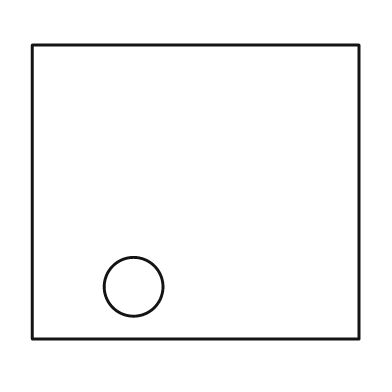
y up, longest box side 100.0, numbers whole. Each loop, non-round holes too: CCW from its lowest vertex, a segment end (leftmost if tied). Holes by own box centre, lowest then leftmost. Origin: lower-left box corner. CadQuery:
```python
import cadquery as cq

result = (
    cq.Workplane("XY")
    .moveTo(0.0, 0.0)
    .lineTo(100.0, 0.0)
    .lineTo(100.0, 90.0)
    .lineTo(0.0, 90.0)
    .close()
    .moveTo(31.0, 16.0)
    .circle(9.0)
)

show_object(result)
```